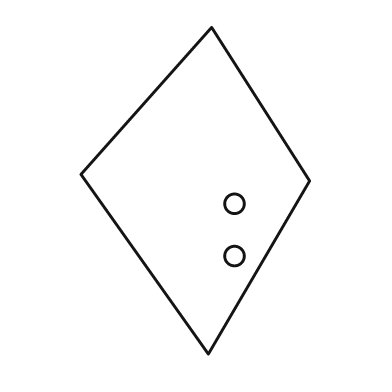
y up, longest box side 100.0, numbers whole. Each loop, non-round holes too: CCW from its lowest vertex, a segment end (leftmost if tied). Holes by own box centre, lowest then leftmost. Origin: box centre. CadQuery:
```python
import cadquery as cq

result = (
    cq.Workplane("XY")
    .moveTo(4.0, -50.0)
    .lineTo(35.0, 3.0)
    .lineTo(5.0, 50.0)
    .lineTo(-35.0, 5.0)
    .close()
    .moveTo(12.0, -20.0)
    .circle(3.0)
    .moveTo(12.0, -4.0)
    .circle(3.0)
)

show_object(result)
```